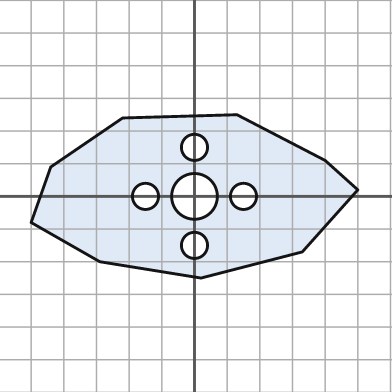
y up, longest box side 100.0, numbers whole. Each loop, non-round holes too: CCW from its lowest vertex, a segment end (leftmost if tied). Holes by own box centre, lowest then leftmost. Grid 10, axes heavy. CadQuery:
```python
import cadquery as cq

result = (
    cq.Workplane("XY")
    .moveTo(2.0, -25.0)
    .lineTo(33.0, -17.0)
    .lineTo(50.0, 2.0)
    .lineTo(40.0, 11.0)
    .lineTo(13.0, 25.0)
    .lineTo(-22.0, 24.0)
    .lineTo(-44.0, 9.0)
    .lineTo(-50.0, -8.0)
    .lineTo(-29.0, -20.0)
    .close()
    .moveTo(0.0, -15.0)
    .circle(4.0)
    .moveTo(-15.0, 0.0)
    .circle(4.0)
    .moveTo(0.0, 0.0)
    .circle(7.0)
    .moveTo(15.0, 0.0)
    .circle(4.0)
    .moveTo(0.0, 15.0)
    .circle(4.0)
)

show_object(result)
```